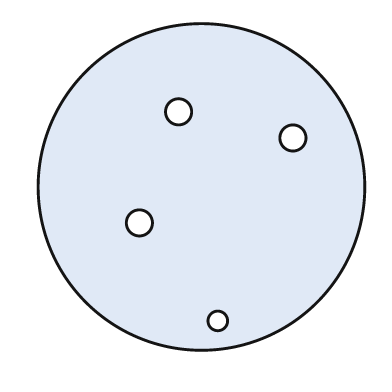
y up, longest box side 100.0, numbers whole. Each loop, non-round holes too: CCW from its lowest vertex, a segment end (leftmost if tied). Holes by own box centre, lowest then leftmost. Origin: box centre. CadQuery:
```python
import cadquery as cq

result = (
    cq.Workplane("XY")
    .moveTo(0.0, 0.0)
    .circle(50.0)
    .moveTo(5.0, -41.0)
    .circle(3.0)
    .moveTo(-19.0, -11.0)
    .circle(4.0)
    .moveTo(28.0, 15.0)
    .circle(4.0)
    .moveTo(-7.0, 23.0)
    .circle(4.0)
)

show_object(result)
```